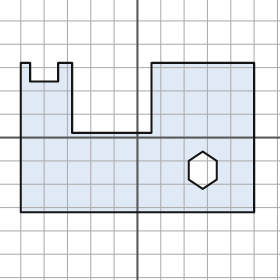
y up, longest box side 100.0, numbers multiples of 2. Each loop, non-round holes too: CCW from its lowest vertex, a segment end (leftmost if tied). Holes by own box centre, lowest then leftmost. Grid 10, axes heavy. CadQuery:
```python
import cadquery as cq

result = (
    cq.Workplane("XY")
    .moveTo(-50.0, -32.0)
    .lineTo(50.0, -32.0)
    .lineTo(50.0, 32.0)
    .lineTo(6.0, 32.0)
    .lineTo(6.0, 2.0)
    .lineTo(-28.0, 2.0)
    .lineTo(-28.0, 32.0)
    .lineTo(-34.0, 32.0)
    .lineTo(-34.0, 24.0)
    .lineTo(-46.0, 24.0)
    .lineTo(-46.0, 32.0)
    .lineTo(-50.0, 32.0)
    .close()
    .moveTo(28.0, -22.0)
    .lineTo(34.0, -18.0)
    .lineTo(34.0, -10.0)
    .lineTo(28.0, -6.0)
    .lineTo(22.0, -10.0)
    .lineTo(22.0, -18.0)
    .close()
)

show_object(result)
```